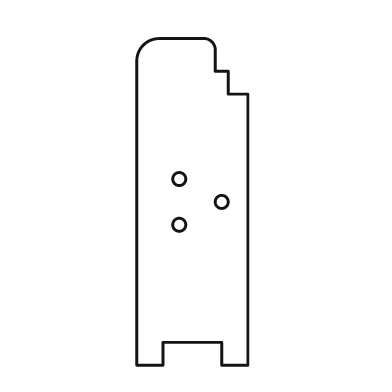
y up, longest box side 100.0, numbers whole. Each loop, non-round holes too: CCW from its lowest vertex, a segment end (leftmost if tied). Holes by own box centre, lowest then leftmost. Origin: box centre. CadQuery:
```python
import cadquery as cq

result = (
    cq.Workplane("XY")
    .moveTo(-17.0, -50.0)
    .lineTo(-9.0, -50.0)
    .lineTo(-9.0, -43.0)
    .lineTo(9.0, -43.0)
    .lineTo(9.0, -50.0)
    .lineTo(17.0, -50.0)
    .lineTo(17.0, 33.0)
    .lineTo(11.0, 33.0)
    .lineTo(11.0, 40.0)
    .lineTo(7.0, 40.0)
    .lineTo(7.0, 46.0)
    .threePointArc((6.0, 49.0), (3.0, 50.0))
    .lineTo(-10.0, 50.0)
    .threePointArc((-15.0, 48.0), (-17.0, 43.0))
    .close()
    .moveTo(-4.0, -7.0)
    .circle(2.0)
    .moveTo(9.0, 0.0)
    .circle(2.0)
    .moveTo(-4.0, 7.0)
    .circle(2.0)
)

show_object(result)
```